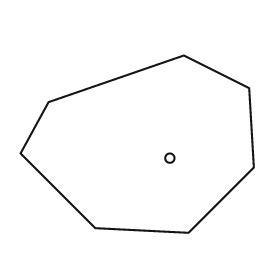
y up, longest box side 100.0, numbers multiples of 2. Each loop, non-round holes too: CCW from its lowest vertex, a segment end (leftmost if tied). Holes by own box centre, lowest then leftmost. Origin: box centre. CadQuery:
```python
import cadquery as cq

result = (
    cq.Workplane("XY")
    .moveTo(22.0, -38.0)
    .lineTo(50.0, -10.0)
    .lineTo(48.0, 24.0)
    .lineTo(20.0, 38.0)
    .lineTo(-38.0, 18.0)
    .lineTo(-50.0, -4.0)
    .lineTo(-18.0, -36.0)
    .close()
    .moveTo(14.0, -6.0)
    .circle(2.0)
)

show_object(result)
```